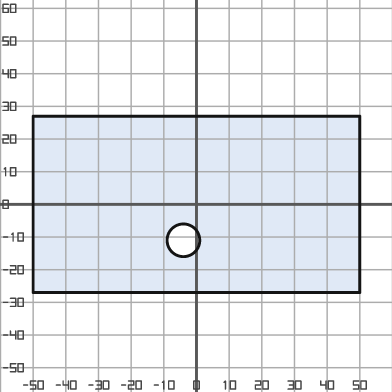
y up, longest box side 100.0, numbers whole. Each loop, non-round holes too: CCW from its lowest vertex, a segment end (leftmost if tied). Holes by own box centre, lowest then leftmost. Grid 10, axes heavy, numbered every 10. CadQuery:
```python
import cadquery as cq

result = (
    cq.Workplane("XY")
    .moveTo(-50.0, -27.0)
    .lineTo(50.0, -27.0)
    .lineTo(50.0, 27.0)
    .lineTo(-50.0, 27.0)
    .close()
    .moveTo(-4.0, -11.0)
    .circle(5.0)
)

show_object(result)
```